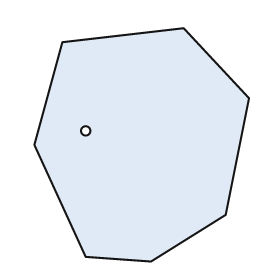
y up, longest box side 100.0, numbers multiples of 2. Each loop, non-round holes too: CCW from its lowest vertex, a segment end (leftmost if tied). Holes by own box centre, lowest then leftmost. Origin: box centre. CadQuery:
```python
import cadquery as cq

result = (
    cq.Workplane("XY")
    .moveTo(4.0, -50.0)
    .lineTo(36.0, -30.0)
    .lineTo(46.0, 20.0)
    .lineTo(18.0, 50.0)
    .lineTo(-34.0, 44.0)
    .lineTo(-46.0, 0.0)
    .lineTo(-24.0, -48.0)
    .close()
    .moveTo(-24.0, 6.0)
    .circle(2.0)
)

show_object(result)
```